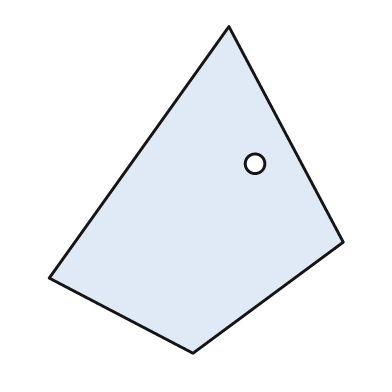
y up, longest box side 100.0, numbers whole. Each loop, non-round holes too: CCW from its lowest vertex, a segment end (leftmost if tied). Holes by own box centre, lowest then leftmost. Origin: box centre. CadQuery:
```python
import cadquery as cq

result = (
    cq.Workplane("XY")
    .moveTo(-1.0, -50.0)
    .lineTo(45.0, -16.0)
    .lineTo(10.0, 50.0)
    .lineTo(-45.0, -27.0)
    .close()
    .moveTo(18.0, 8.0)
    .circle(3.0)
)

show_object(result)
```